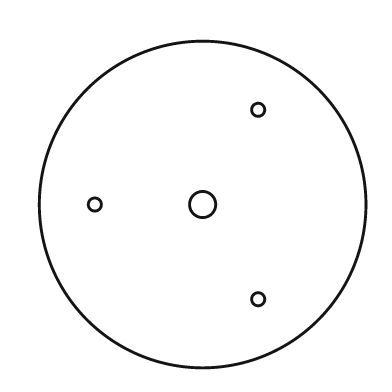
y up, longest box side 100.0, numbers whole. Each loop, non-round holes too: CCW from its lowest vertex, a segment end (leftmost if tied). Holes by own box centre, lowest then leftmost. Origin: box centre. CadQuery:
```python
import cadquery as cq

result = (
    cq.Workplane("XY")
    .moveTo(0.0, 0.0)
    .circle(50.0)
    .moveTo(17.0, -29.0)
    .circle(2.0)
    .moveTo(-33.0, 0.0)
    .circle(2.0)
    .moveTo(0.0, 0.0)
    .circle(4.0)
    .moveTo(17.0, 29.0)
    .circle(2.0)
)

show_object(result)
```